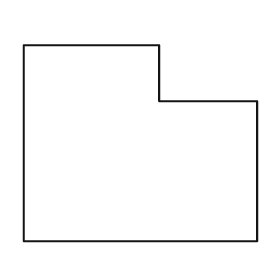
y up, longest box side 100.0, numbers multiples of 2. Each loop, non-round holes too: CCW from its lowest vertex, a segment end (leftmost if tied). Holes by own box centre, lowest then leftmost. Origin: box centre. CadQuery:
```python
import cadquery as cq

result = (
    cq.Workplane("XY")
    .moveTo(-50.0, -42.0)
    .lineTo(50.0, -42.0)
    .lineTo(50.0, 18.0)
    .lineTo(8.0, 18.0)
    .lineTo(8.0, 42.0)
    .lineTo(-50.0, 42.0)
    .close()
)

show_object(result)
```